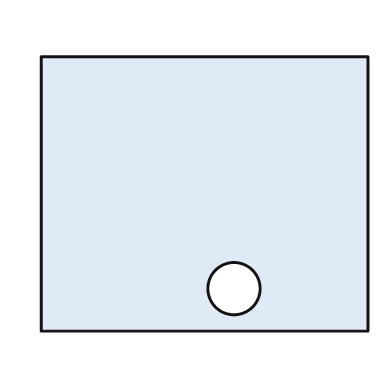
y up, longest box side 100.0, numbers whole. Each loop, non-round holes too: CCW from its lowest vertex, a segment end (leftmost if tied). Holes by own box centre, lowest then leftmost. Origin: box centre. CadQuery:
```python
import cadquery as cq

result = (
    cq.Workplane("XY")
    .moveTo(-50.0, -42.0)
    .lineTo(50.0, -42.0)
    .lineTo(50.0, 42.0)
    .lineTo(-50.0, 42.0)
    .close()
    .moveTo(9.0, -29.0)
    .circle(8.0)
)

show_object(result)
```